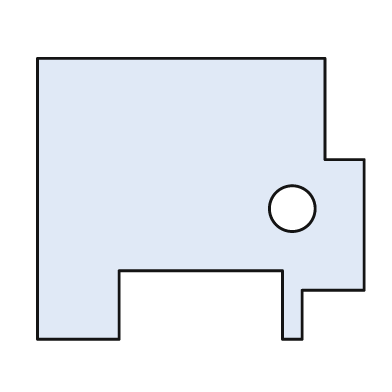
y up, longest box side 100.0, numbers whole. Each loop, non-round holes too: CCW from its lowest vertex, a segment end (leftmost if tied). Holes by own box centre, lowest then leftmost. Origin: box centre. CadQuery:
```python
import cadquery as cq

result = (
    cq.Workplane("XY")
    .moveTo(-50.0, -43.0)
    .lineTo(-25.0, -43.0)
    .lineTo(-25.0, -22.0)
    .lineTo(25.0, -22.0)
    .lineTo(25.0, -43.0)
    .lineTo(31.0, -43.0)
    .lineTo(31.0, -28.0)
    .lineTo(50.0, -28.0)
    .lineTo(50.0, 12.0)
    .lineTo(38.0, 12.0)
    .lineTo(38.0, 43.0)
    .lineTo(-50.0, 43.0)
    .close()
    .moveTo(28.0, -3.0)
    .circle(7.0)
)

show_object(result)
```